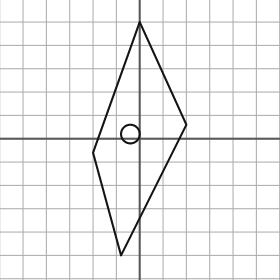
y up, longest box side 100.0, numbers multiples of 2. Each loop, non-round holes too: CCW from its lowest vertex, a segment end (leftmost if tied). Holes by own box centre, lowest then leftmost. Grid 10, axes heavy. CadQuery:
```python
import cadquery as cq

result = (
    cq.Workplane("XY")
    .moveTo(-8.0, -50.0)
    .lineTo(20.0, 6.0)
    .lineTo(0.0, 50.0)
    .lineTo(-20.0, -6.0)
    .close()
    .moveTo(-4.0, 2.0)
    .circle(4.0)
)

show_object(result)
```